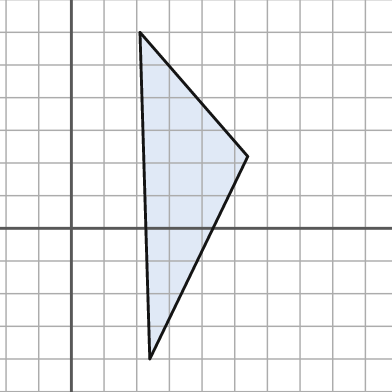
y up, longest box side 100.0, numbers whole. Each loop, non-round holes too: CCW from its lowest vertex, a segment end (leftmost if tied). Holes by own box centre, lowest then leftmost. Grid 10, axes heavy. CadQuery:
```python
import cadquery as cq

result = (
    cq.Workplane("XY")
    .moveTo(24.0, -40.0)
    .lineTo(54.0, 22.0)
    .lineTo(21.0, 60.0)
    .close()
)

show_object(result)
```